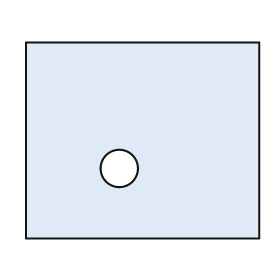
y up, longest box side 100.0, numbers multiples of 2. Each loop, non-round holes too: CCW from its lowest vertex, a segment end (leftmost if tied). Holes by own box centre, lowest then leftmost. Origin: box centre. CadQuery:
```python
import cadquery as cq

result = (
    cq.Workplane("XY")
    .moveTo(-50.0, -42.0)
    .lineTo(50.0, -42.0)
    .lineTo(50.0, 42.0)
    .lineTo(-50.0, 42.0)
    .close()
    .moveTo(-10.0, -12.0)
    .circle(8.0)
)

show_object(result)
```